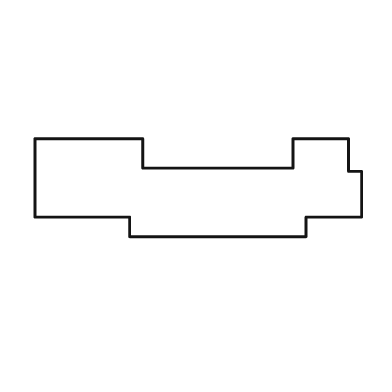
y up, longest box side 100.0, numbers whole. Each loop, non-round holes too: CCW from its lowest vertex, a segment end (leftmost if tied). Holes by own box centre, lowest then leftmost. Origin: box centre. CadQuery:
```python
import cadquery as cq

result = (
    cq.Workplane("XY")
    .moveTo(-21.0, -15.0)
    .lineTo(33.0, -15.0)
    .lineTo(33.0, -9.0)
    .lineTo(50.0, -9.0)
    .lineTo(50.0, 5.0)
    .lineTo(46.0, 5.0)
    .lineTo(46.0, 15.0)
    .lineTo(29.0, 15.0)
    .lineTo(29.0, 6.0)
    .lineTo(-17.0, 6.0)
    .lineTo(-17.0, 15.0)
    .lineTo(-50.0, 15.0)
    .lineTo(-50.0, -9.0)
    .lineTo(-21.0, -9.0)
    .close()
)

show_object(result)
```